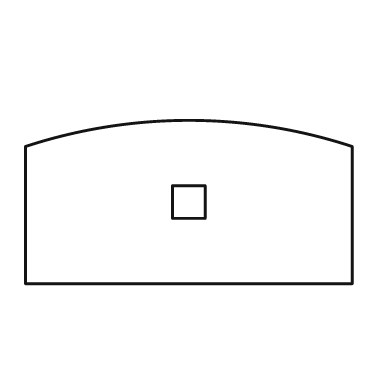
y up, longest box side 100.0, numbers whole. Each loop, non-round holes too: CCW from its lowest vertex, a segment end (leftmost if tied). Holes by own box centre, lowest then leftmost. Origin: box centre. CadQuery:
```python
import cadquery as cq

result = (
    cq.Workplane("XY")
    .moveTo(-50.0, -25.0)
    .lineTo(50.0, -25.0)
    .lineTo(50.0, 17.0)
    .threePointArc((0.0, 25.0), (-50.0, 17.0))
    .close()
    .moveTo(-5.0, -5.0)
    .lineTo(5.0, -5.0)
    .lineTo(5.0, 5.0)
    .lineTo(-5.0, 5.0)
    .close()
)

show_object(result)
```